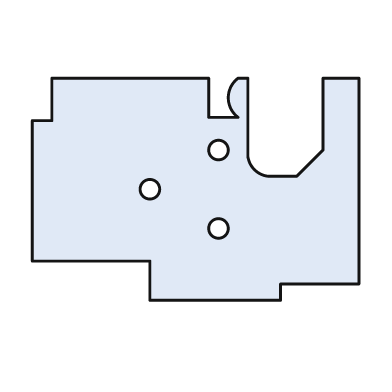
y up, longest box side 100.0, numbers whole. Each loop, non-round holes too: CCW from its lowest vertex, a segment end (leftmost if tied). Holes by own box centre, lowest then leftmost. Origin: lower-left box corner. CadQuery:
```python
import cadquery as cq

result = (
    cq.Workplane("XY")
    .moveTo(36.0, 0.0)
    .lineTo(76.0, 0.0)
    .lineTo(76.0, 5.0)
    .lineTo(100.0, 5.0)
    .lineTo(100.0, 68.0)
    .lineTo(89.0, 68.0)
    .lineTo(89.0, 46.0)
    .lineTo(81.0, 38.0)
    .lineTo(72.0, 38.0)
    .threePointArc((68.0, 40.0), (66.0, 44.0))
    .lineTo(66.0, 68.0)
    .lineTo(63.0, 68.0)
    .threePointArc((60.0, 62.0), (63.0, 56.0))
    .lineTo(54.0, 56.0)
    .lineTo(54.0, 68.0)
    .lineTo(6.0, 68.0)
    .lineTo(6.0, 55.0)
    .lineTo(0.0, 55.0)
    .lineTo(0.0, 12.0)
    .lineTo(36.0, 12.0)
    .close()
    .moveTo(57.0, 22.0)
    .circle(3.0)
    .moveTo(36.0, 34.0)
    .circle(3.0)
    .moveTo(57.0, 46.0)
    .circle(3.0)
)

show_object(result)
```